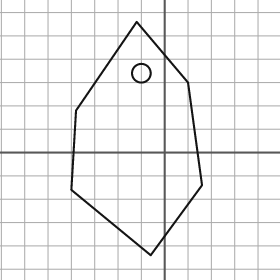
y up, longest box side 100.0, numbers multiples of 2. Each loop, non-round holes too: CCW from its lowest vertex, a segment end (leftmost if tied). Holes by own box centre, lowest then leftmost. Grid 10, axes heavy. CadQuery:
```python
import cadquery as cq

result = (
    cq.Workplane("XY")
    .moveTo(-6.0, -44.0)
    .lineTo(16.0, -14.0)
    .lineTo(10.0, 30.0)
    .lineTo(-12.0, 56.0)
    .lineTo(-38.0, 18.0)
    .lineTo(-40.0, -16.0)
    .close()
    .moveTo(-10.0, 34.0)
    .circle(4.0)
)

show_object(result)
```